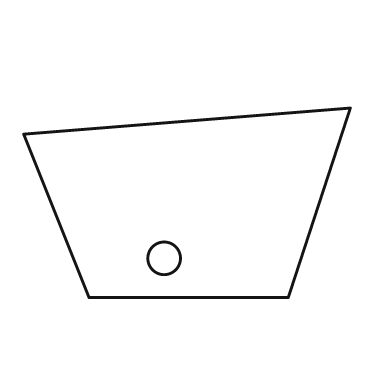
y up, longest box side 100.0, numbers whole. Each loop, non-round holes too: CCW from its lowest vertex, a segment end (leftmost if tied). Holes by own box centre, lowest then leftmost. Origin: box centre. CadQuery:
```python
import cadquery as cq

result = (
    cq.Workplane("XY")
    .moveTo(-30.0, -29.0)
    .lineTo(31.0, -29.0)
    .lineTo(50.0, 29.0)
    .lineTo(-50.0, 21.0)
    .close()
    .moveTo(-7.0, -17.0)
    .circle(5.0)
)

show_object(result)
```